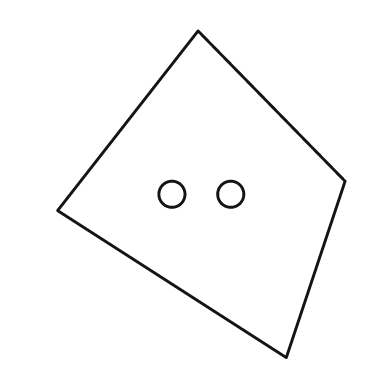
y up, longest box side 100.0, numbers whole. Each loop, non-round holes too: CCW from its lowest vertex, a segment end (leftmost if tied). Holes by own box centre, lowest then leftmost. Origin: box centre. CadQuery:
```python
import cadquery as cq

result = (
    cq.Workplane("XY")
    .moveTo(26.0, -50.0)
    .lineTo(44.0, 4.0)
    .lineTo(-1.0, 50.0)
    .lineTo(-44.0, -5.0)
    .close()
    .moveTo(-9.0, 0.0)
    .circle(4.0)
    .moveTo(9.0, 0.0)
    .circle(4.0)
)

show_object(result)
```